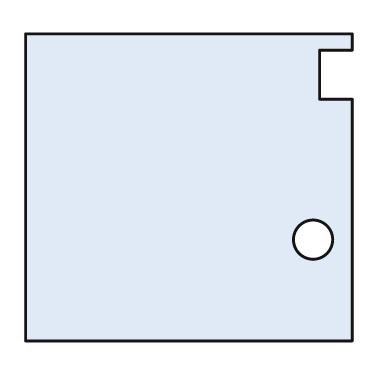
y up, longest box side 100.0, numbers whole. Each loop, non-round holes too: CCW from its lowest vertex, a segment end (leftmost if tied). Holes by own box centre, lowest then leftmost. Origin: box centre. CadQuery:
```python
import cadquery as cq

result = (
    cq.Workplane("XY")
    .moveTo(-50.0, -47.0)
    .lineTo(50.0, -47.0)
    .lineTo(50.0, 27.0)
    .lineTo(40.0, 27.0)
    .lineTo(40.0, 42.0)
    .lineTo(50.0, 42.0)
    .lineTo(50.0, 47.0)
    .lineTo(-50.0, 47.0)
    .close()
    .moveTo(38.0, -16.0)
    .circle(6.0)
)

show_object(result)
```